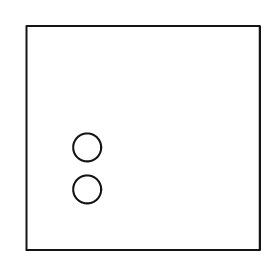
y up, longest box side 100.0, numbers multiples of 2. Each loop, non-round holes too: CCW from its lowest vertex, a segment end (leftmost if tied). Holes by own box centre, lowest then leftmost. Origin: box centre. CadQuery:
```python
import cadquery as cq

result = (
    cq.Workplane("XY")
    .moveTo(-50.0, -48.0)
    .lineTo(50.0, -48.0)
    .lineTo(50.0, 48.0)
    .lineTo(-50.0, 48.0)
    .close()
    .moveTo(-24.0, -22.0)
    .circle(6.0)
    .moveTo(-24.0, -4.0)
    .circle(6.0)
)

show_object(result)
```